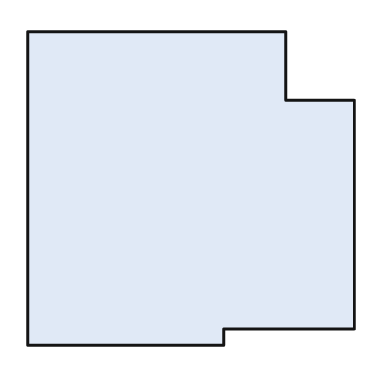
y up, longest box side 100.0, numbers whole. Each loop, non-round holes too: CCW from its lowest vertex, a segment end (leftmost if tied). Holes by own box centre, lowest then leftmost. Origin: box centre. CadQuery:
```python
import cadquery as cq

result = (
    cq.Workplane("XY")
    .moveTo(-50.0, -48.0)
    .lineTo(10.0, -48.0)
    .lineTo(10.0, -43.0)
    .lineTo(50.0, -43.0)
    .lineTo(50.0, 27.0)
    .lineTo(29.0, 27.0)
    .lineTo(29.0, 48.0)
    .lineTo(-50.0, 48.0)
    .close()
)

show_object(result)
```